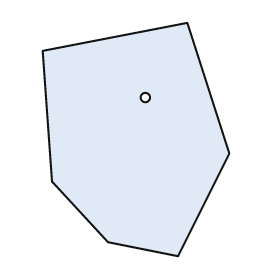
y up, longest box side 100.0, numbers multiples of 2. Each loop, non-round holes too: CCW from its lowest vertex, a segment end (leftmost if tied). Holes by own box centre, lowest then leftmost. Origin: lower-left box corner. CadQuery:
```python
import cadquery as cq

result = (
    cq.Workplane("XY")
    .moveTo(58.0, 0.0)
    .lineTo(80.0, 44.0)
    .lineTo(62.0, 100.0)
    .lineTo(0.0, 88.0)
    .lineTo(4.0, 32.0)
    .lineTo(28.0, 6.0)
    .close()
    .moveTo(44.0, 68.0)
    .circle(2.0)
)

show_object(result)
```